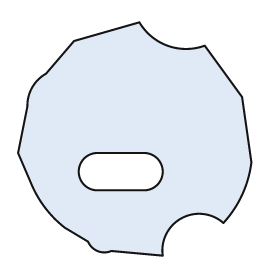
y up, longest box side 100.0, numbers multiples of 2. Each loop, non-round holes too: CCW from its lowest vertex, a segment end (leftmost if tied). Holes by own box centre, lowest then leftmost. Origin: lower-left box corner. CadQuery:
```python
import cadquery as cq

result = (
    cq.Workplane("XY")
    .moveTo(62.0, 0.0)
    .threePointArc((70.0, 16.0), (88.0, 14.0))
    .threePointArc((96.0, 26.0), (100.0, 40.0))
    .lineTo(96.0, 68.0)
    .lineTo(80.0, 90.0)
    .threePointArc((64.0, 90.0), (52.0, 100.0))
    .lineTo(24.0, 92.0)
    .lineTo(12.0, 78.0)
    .threePointArc((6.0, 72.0), (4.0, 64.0))
    .lineTo(0.0, 44.0)
    .lineTo(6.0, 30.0)
    .threePointArc((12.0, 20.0), (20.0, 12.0))
    .lineTo(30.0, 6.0)
    .threePointArc((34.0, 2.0), (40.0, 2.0))
    .close()
    .moveTo(34.0, 28.0)
    .lineTo(54.0, 28.0)
    .threePointArc((62.0, 36.0), (54.0, 44.0))
    .lineTo(34.0, 44.0)
    .threePointArc((26.0, 36.0), (34.0, 28.0))
    .close()
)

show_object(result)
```